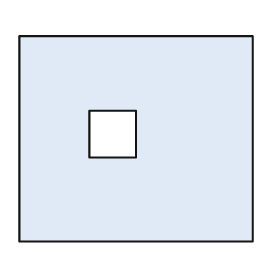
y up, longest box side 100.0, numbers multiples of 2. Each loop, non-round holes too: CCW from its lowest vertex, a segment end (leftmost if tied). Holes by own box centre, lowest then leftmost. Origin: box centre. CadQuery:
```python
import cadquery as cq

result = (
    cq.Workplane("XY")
    .moveTo(-50.0, -44.0)
    .lineTo(50.0, -44.0)
    .lineTo(50.0, 44.0)
    .lineTo(-50.0, 44.0)
    .close()
    .moveTo(-20.0, -8.0)
    .lineTo(0.0, -8.0)
    .lineTo(0.0, 12.0)
    .lineTo(-20.0, 12.0)
    .close()
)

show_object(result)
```